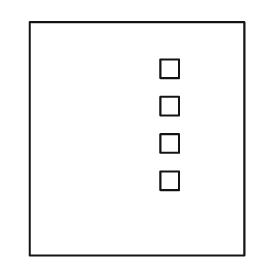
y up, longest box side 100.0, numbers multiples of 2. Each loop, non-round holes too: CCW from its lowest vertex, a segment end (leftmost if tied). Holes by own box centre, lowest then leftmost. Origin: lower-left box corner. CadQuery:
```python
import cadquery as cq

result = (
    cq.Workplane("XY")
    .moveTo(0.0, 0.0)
    .lineTo(92.0, 0.0)
    .lineTo(92.0, 100.0)
    .lineTo(0.0, 100.0)
    .close()
    .moveTo(56.0, 28.0)
    .lineTo(64.0, 28.0)
    .lineTo(64.0, 36.0)
    .lineTo(56.0, 36.0)
    .close()
    .moveTo(56.0, 44.0)
    .lineTo(64.0, 44.0)
    .lineTo(64.0, 52.0)
    .lineTo(56.0, 52.0)
    .close()
    .moveTo(56.0, 60.0)
    .lineTo(64.0, 60.0)
    .lineTo(64.0, 68.0)
    .lineTo(56.0, 68.0)
    .close()
    .moveTo(56.0, 76.0)
    .lineTo(64.0, 76.0)
    .lineTo(64.0, 84.0)
    .lineTo(56.0, 84.0)
    .close()
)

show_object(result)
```